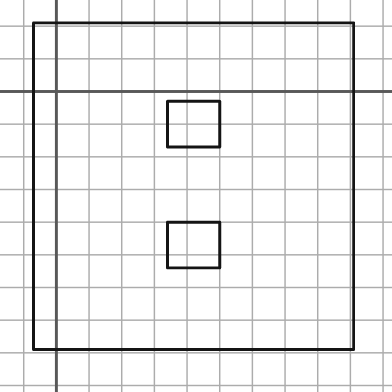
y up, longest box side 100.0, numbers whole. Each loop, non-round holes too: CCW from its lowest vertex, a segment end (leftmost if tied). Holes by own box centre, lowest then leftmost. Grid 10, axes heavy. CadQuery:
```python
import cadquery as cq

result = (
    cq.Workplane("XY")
    .moveTo(-7.0, -79.0)
    .lineTo(91.0, -79.0)
    .lineTo(91.0, 21.0)
    .lineTo(-7.0, 21.0)
    .close()
    .moveTo(34.0, -54.0)
    .lineTo(50.0, -54.0)
    .lineTo(50.0, -40.0)
    .lineTo(34.0, -40.0)
    .close()
    .moveTo(34.0, -17.0)
    .lineTo(50.0, -17.0)
    .lineTo(50.0, -3.0)
    .lineTo(34.0, -3.0)
    .close()
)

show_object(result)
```